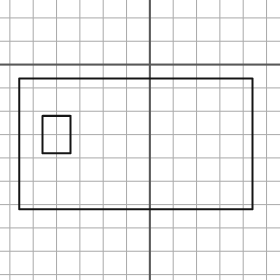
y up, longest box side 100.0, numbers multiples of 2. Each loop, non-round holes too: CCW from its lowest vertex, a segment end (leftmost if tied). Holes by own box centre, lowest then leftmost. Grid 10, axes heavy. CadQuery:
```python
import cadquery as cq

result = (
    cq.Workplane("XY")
    .moveTo(-56.0, -62.0)
    .lineTo(44.0, -62.0)
    .lineTo(44.0, -6.0)
    .lineTo(-56.0, -6.0)
    .close()
    .moveTo(-46.0, -38.0)
    .lineTo(-34.0, -38.0)
    .lineTo(-34.0, -22.0)
    .lineTo(-46.0, -22.0)
    .close()
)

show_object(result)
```